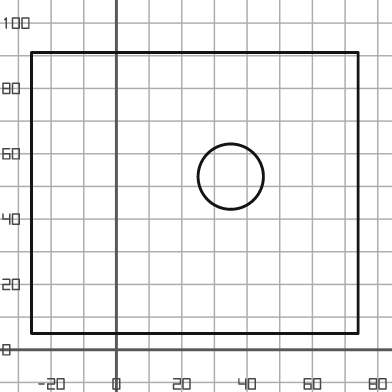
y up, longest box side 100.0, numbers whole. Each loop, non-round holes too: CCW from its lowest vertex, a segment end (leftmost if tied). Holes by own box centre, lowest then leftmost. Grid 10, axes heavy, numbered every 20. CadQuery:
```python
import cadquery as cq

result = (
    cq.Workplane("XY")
    .moveTo(-26.0, 5.0)
    .lineTo(74.0, 5.0)
    .lineTo(74.0, 91.0)
    .lineTo(-26.0, 91.0)
    .close()
    .moveTo(35.0, 53.0)
    .circle(10.0)
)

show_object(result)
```